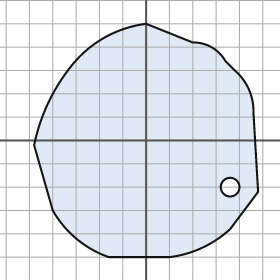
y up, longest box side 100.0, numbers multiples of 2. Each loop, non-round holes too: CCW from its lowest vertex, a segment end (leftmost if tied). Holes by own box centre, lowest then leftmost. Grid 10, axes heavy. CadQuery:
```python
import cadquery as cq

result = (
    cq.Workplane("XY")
    .moveTo(-16.0, -50.0)
    .lineTo(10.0, -50.0)
    .threePointArc((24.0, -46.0), (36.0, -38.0))
    .lineTo(48.0, -22.0)
    .lineTo(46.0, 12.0)
    .threePointArc((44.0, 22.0), (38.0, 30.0))
    .lineTo(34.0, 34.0)
    .threePointArc((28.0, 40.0), (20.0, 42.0))
    .lineTo(0.0, 50.0)
    .threePointArc((-18.0, 44.0), (-32.0, 32.0))
    .threePointArc((-42.0, 16.0), (-48.0, -2.0))
    .lineTo(-40.0, -30.0)
    .threePointArc((-30.0, -42.0), (-16.0, -50.0))
    .close()
    .moveTo(36.0, -20.0)
    .circle(4.0)
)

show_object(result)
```